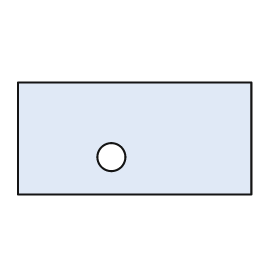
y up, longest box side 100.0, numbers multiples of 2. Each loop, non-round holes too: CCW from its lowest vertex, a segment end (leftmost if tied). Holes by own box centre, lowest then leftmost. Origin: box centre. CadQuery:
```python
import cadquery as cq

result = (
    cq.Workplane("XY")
    .moveTo(-50.0, -24.0)
    .lineTo(50.0, -24.0)
    .lineTo(50.0, 24.0)
    .lineTo(-50.0, 24.0)
    .close()
    .moveTo(-10.0, -8.0)
    .circle(6.0)
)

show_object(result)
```